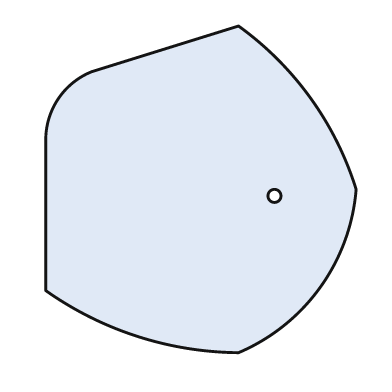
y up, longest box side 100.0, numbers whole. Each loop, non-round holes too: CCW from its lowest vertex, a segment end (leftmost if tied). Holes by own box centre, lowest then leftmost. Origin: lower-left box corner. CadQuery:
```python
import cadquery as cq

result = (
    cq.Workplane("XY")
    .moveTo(59.0, 0.0)
    .threePointArc((84.0, 20.0), (95.0, 50.0))
    .threePointArc((81.0, 78.0), (59.0, 100.0))
    .lineTo(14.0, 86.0)
    .threePointArc((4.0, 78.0), (0.0, 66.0))
    .lineTo(0.0, 19.0)
    .threePointArc((28.0, 5.0), (59.0, 0.0))
    .close()
    .moveTo(70.0, 48.0)
    .circle(2.0)
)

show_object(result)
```